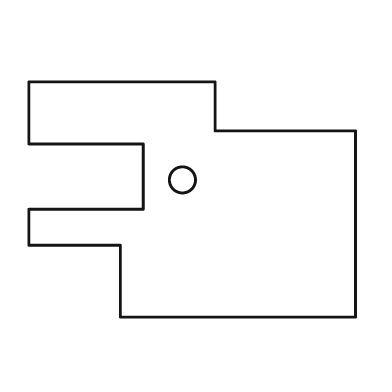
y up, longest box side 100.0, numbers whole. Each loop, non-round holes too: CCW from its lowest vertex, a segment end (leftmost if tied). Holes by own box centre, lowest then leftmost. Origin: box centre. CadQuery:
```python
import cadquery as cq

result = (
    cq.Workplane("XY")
    .moveTo(-22.0, -36.0)
    .lineTo(50.0, -36.0)
    .lineTo(50.0, 21.0)
    .lineTo(7.0, 21.0)
    .lineTo(7.0, 36.0)
    .lineTo(-50.0, 36.0)
    .lineTo(-50.0, 17.0)
    .lineTo(-15.0, 17.0)
    .lineTo(-15.0, -3.0)
    .lineTo(-50.0, -3.0)
    .lineTo(-50.0, -14.0)
    .lineTo(-22.0, -14.0)
    .close()
    .moveTo(-3.0, 6.0)
    .circle(4.0)
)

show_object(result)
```